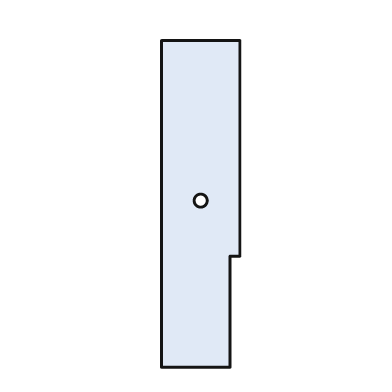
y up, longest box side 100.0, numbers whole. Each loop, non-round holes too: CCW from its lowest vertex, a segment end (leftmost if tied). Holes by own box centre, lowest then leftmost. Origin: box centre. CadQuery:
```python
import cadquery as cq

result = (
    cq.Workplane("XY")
    .moveTo(-12.0, -50.0)
    .lineTo(9.0, -50.0)
    .lineTo(9.0, -16.0)
    .lineTo(12.0, -16.0)
    .lineTo(12.0, 50.0)
    .lineTo(-12.0, 50.0)
    .close()
    .moveTo(0.0, 1.0)
    .circle(2.0)
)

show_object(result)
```